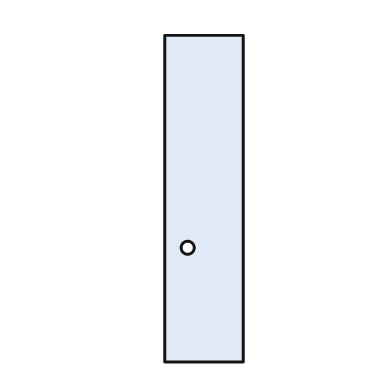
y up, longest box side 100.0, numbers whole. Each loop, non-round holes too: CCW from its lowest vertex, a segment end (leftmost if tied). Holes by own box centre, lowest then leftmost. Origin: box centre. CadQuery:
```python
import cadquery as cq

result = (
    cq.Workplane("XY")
    .moveTo(-12.0, -50.0)
    .lineTo(12.0, -50.0)
    .lineTo(12.0, 50.0)
    .lineTo(-12.0, 50.0)
    .close()
    .moveTo(-5.0, -15.0)
    .circle(2.0)
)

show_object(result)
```